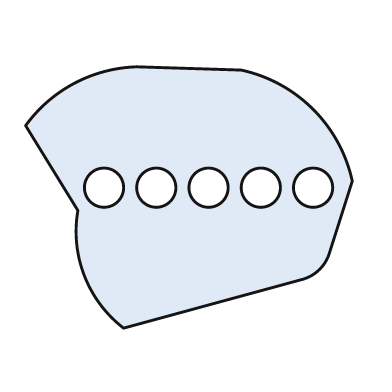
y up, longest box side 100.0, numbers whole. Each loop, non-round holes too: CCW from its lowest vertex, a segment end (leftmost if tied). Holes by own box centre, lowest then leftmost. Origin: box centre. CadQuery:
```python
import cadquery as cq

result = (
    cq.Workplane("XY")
    .moveTo(-20.0, -40.0)
    .lineTo(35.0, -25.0)
    .threePointArc((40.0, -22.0), (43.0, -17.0))
    .lineTo(50.0, 5.0)
    .threePointArc((38.0, 27.0), (16.0, 39.0))
    .lineTo(-16.0, 40.0)
    .threePointArc((-35.0, 35.0), (-50.0, 22.0))
    .lineTo(-34.0, -4.0)
    .threePointArc((-32.0, -24.0), (-20.0, -40.0))
    .close()
    .moveTo(-26.0, 3.0)
    .circle(6.0)
    .moveTo(-10.0, 3.0)
    .circle(6.0)
    .moveTo(6.0, 3.0)
    .circle(6.0)
    .moveTo(22.0, 3.0)
    .circle(6.0)
    .moveTo(38.0, 3.0)
    .circle(6.0)
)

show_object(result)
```